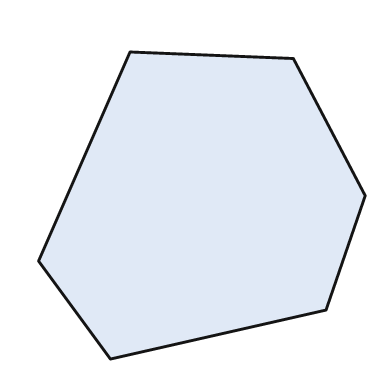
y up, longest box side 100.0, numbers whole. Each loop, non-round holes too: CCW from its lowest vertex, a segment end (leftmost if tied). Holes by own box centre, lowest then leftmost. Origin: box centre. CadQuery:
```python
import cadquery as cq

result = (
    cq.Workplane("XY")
    .moveTo(-28.0, -47.0)
    .lineTo(38.0, -32.0)
    .lineTo(50.0, 3.0)
    .lineTo(28.0, 45.0)
    .lineTo(-22.0, 47.0)
    .lineTo(-50.0, -17.0)
    .close()
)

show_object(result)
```